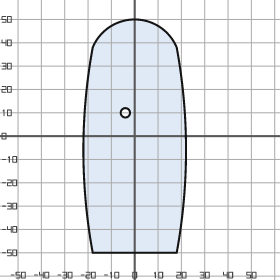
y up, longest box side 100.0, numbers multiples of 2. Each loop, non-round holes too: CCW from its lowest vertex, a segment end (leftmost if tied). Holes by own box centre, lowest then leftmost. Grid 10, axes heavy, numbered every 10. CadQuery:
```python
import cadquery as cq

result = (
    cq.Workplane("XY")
    .moveTo(-18.0, -50.0)
    .lineTo(18.0, -50.0)
    .threePointArc((22.0, -6.0), (18.0, 38.0))
    .threePointArc((0.0, 50.0), (-18.0, 38.0))
    .threePointArc((-22.0, -6.0), (-18.0, -50.0))
    .close()
    .moveTo(-4.0, 10.0)
    .circle(2.0)
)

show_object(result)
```